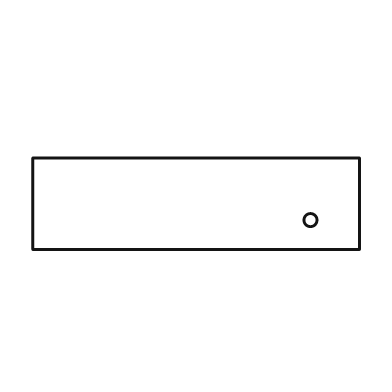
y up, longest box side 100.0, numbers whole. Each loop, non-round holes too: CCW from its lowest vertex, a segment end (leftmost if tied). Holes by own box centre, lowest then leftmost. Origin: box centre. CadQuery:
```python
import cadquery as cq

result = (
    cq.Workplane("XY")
    .moveTo(-50.0, -14.0)
    .lineTo(50.0, -14.0)
    .lineTo(50.0, 14.0)
    .lineTo(-50.0, 14.0)
    .close()
    .moveTo(35.0, -5.0)
    .circle(2.0)
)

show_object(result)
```